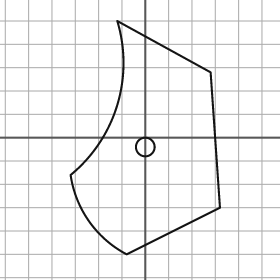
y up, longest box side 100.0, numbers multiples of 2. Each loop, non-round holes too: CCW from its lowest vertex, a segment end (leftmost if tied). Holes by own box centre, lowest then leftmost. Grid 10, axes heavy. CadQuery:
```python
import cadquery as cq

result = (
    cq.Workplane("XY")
    .moveTo(-8.0, -50.0)
    .lineTo(32.0, -30.0)
    .lineTo(28.0, 28.0)
    .lineTo(-12.0, 50.0)
    .threePointArc((-12.0, 14.0), (-32.0, -16.0))
    .threePointArc((-24.0, -36.0), (-8.0, -50.0))
    .close()
    .moveTo(0.0, -4.0)
    .circle(4.0)
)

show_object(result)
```